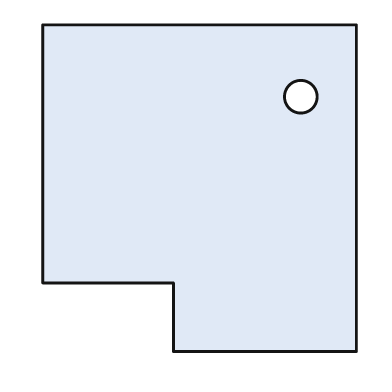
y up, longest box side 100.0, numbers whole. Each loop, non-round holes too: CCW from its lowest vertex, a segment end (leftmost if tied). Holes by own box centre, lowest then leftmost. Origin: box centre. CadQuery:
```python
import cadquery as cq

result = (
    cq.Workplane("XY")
    .moveTo(-8.0, -50.0)
    .lineTo(48.0, -50.0)
    .lineTo(48.0, 50.0)
    .lineTo(-48.0, 50.0)
    .lineTo(-48.0, -29.0)
    .lineTo(-8.0, -29.0)
    .close()
    .moveTo(31.0, 28.0)
    .circle(5.0)
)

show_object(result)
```